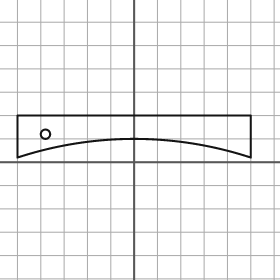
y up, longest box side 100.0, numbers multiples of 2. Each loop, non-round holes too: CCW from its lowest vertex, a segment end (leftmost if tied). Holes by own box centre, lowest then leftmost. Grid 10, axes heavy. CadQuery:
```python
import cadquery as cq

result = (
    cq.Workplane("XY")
    .moveTo(-50.0, 2.0)
    .threePointArc((0.0, 10.0), (50.0, 2.0))
    .lineTo(50.0, 20.0)
    .lineTo(-50.0, 20.0)
    .close()
    .moveTo(-38.0, 12.0)
    .circle(2.0)
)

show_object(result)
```